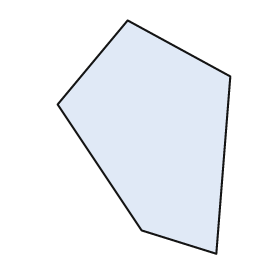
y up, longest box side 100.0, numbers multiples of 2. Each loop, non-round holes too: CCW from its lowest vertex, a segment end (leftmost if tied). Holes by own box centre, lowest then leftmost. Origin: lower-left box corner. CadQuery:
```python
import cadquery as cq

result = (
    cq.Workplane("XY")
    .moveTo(68.0, 0.0)
    .lineTo(74.0, 76.0)
    .lineTo(30.0, 100.0)
    .lineTo(0.0, 64.0)
    .lineTo(36.0, 10.0)
    .close()
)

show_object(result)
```